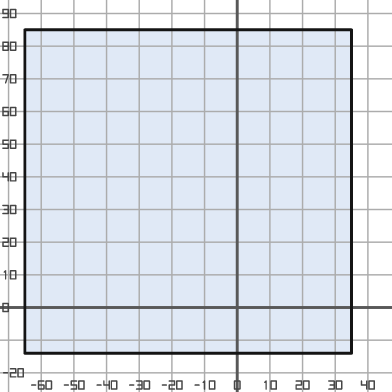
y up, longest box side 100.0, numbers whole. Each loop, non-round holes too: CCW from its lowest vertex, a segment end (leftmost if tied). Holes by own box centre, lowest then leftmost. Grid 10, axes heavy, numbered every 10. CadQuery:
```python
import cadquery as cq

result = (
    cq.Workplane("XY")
    .moveTo(-65.0, -14.0)
    .lineTo(35.0, -14.0)
    .lineTo(35.0, 85.0)
    .lineTo(-65.0, 85.0)
    .close()
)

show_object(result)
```